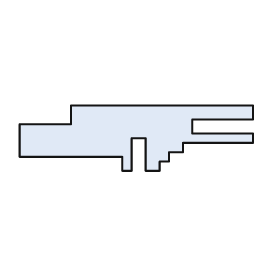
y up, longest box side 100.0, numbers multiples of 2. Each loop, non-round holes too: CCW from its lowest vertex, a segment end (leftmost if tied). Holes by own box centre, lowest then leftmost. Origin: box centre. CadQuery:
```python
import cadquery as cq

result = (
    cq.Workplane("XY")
    .moveTo(-6.0, -14.0)
    .lineTo(-2.0, -14.0)
    .lineTo(-2.0, 0.0)
    .lineTo(4.0, 0.0)
    .lineTo(4.0, -14.0)
    .lineTo(10.0, -14.0)
    .lineTo(10.0, -10.0)
    .lineTo(14.0, -10.0)
    .lineTo(14.0, -6.0)
    .lineTo(20.0, -6.0)
    .lineTo(20.0, -2.0)
    .lineTo(50.0, -2.0)
    .lineTo(50.0, 2.0)
    .lineTo(24.0, 2.0)
    .lineTo(24.0, 8.0)
    .lineTo(50.0, 8.0)
    .lineTo(50.0, 14.0)
    .lineTo(-28.0, 14.0)
    .lineTo(-28.0, 6.0)
    .lineTo(-50.0, 6.0)
    .lineTo(-50.0, -8.0)
    .lineTo(-6.0, -8.0)
    .close()
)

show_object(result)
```